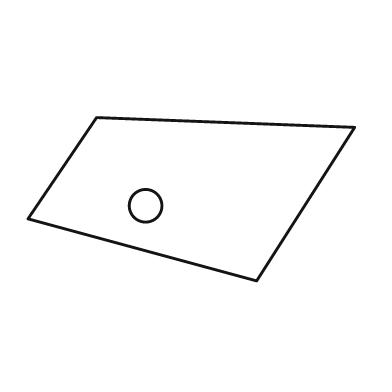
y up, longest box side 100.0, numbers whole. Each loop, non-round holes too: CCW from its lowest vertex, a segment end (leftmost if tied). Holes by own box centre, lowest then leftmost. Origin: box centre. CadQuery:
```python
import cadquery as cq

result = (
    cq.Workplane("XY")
    .moveTo(20.0, -25.0)
    .lineTo(50.0, 22.0)
    .lineTo(-29.0, 25.0)
    .lineTo(-50.0, -6.0)
    .close()
    .moveTo(-14.0, -2.0)
    .circle(5.0)
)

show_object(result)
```